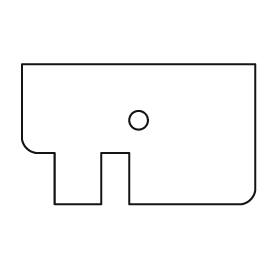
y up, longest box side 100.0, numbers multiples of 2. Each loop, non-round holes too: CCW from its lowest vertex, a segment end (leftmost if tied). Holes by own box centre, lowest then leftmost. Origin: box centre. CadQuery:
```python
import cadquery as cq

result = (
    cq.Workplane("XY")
    .moveTo(-36.0, -30.0)
    .lineTo(-16.0, -30.0)
    .lineTo(-16.0, -8.0)
    .lineTo(-4.0, -8.0)
    .lineTo(-4.0, -30.0)
    .lineTo(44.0, -30.0)
    .threePointArc((48.0, -28.0), (50.0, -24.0))
    .lineTo(50.0, 30.0)
    .lineTo(-50.0, 30.0)
    .lineTo(-50.0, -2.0)
    .threePointArc((-48.0, -6.0), (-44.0, -8.0))
    .lineTo(-36.0, -8.0)
    .close()
    .moveTo(0.0, 6.0)
    .circle(4.0)
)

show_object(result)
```